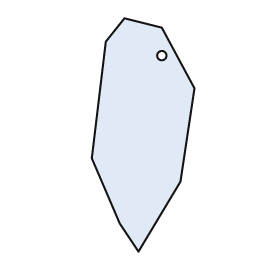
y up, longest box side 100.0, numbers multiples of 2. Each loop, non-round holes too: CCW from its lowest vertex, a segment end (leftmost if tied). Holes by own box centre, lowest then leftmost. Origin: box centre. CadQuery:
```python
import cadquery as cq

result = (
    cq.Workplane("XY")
    .moveTo(-2.0, -50.0)
    .lineTo(16.0, -20.0)
    .lineTo(22.0, 20.0)
    .lineTo(8.0, 46.0)
    .lineTo(-8.0, 50.0)
    .lineTo(-16.0, 40.0)
    .lineTo(-22.0, -10.0)
    .lineTo(-10.0, -38.0)
    .close()
    .moveTo(8.0, 34.0)
    .circle(2.0)
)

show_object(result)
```